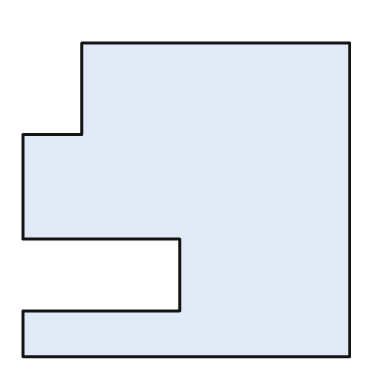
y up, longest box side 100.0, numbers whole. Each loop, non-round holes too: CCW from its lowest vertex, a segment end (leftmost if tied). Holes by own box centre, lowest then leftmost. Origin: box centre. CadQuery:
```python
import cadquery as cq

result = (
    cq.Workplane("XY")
    .moveTo(-50.0, -48.0)
    .lineTo(50.0, -48.0)
    .lineTo(50.0, 48.0)
    .lineTo(-32.0, 48.0)
    .lineTo(-32.0, 20.0)
    .lineTo(-50.0, 20.0)
    .lineTo(-50.0, -12.0)
    .lineTo(-2.0, -12.0)
    .lineTo(-2.0, -34.0)
    .lineTo(-50.0, -34.0)
    .close()
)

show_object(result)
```